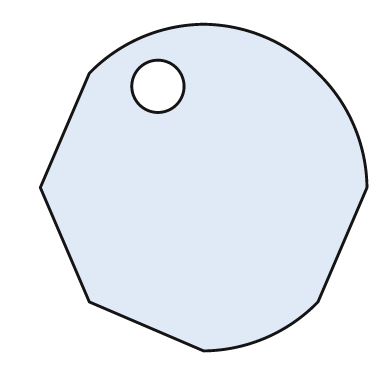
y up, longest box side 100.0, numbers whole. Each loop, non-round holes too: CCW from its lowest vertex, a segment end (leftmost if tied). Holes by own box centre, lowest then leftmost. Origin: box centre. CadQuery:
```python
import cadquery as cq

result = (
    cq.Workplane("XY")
    .moveTo(0.0, -50.0)
    .threePointArc((19.0, -46.0), (35.0, -35.0))
    .lineTo(50.0, 0.0)
    .threePointArc((46.0, 19.0), (35.0, 35.0))
    .threePointArc((19.0, 46.0), (0.0, 50.0))
    .threePointArc((-19.0, 46.0), (-35.0, 35.0))
    .lineTo(-50.0, 0.0)
    .lineTo(-35.0, -35.0)
    .close()
    .moveTo(-14.0, 31.0)
    .circle(8.0)
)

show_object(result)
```